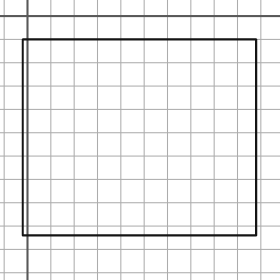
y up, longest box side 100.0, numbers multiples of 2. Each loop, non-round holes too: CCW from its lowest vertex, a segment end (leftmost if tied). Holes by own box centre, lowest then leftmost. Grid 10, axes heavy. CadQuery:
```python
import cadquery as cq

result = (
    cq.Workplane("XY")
    .moveTo(-2.0, -94.0)
    .lineTo(98.0, -94.0)
    .lineTo(98.0, -10.0)
    .lineTo(-2.0, -10.0)
    .close()
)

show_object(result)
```